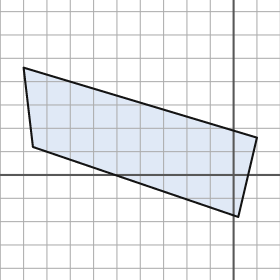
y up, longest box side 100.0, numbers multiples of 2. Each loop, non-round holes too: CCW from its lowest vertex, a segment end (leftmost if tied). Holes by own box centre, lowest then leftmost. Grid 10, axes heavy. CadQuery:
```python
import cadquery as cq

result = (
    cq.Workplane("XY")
    .moveTo(2.0, -18.0)
    .lineTo(10.0, 16.0)
    .lineTo(-90.0, 46.0)
    .lineTo(-86.0, 12.0)
    .close()
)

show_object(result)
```